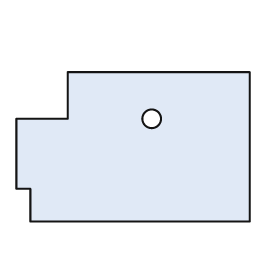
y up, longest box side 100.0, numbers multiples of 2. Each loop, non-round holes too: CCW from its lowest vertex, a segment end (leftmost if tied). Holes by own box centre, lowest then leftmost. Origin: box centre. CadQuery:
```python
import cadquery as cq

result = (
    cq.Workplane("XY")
    .moveTo(-44.0, -32.0)
    .lineTo(50.0, -32.0)
    .lineTo(50.0, 32.0)
    .lineTo(-28.0, 32.0)
    .lineTo(-28.0, 12.0)
    .lineTo(-50.0, 12.0)
    .lineTo(-50.0, -18.0)
    .lineTo(-44.0, -18.0)
    .close()
    .moveTo(8.0, 12.0)
    .circle(4.0)
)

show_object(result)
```